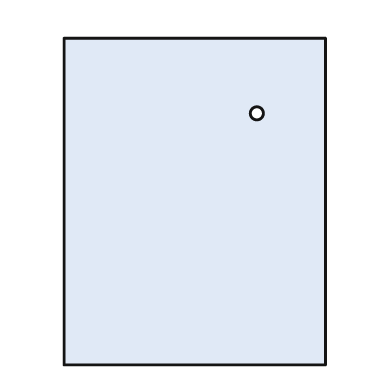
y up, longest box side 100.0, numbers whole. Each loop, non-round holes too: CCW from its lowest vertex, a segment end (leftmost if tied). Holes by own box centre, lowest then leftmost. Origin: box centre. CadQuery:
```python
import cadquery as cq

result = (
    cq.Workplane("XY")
    .moveTo(-40.0, -50.0)
    .lineTo(40.0, -50.0)
    .lineTo(40.0, 50.0)
    .lineTo(-40.0, 50.0)
    .close()
    .moveTo(19.0, 27.0)
    .circle(2.0)
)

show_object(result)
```